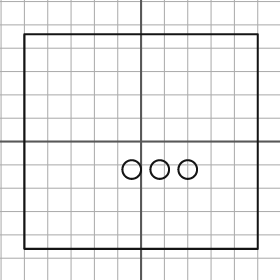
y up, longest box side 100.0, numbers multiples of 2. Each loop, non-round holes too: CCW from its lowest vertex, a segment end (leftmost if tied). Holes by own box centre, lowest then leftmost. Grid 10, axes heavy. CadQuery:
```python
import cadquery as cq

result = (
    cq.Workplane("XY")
    .moveTo(-50.0, -46.0)
    .lineTo(50.0, -46.0)
    .lineTo(50.0, 46.0)
    .lineTo(-50.0, 46.0)
    .close()
    .moveTo(-4.0, -12.0)
    .circle(4.0)
    .moveTo(8.0, -12.0)
    .circle(4.0)
    .moveTo(20.0, -12.0)
    .circle(4.0)
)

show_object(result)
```